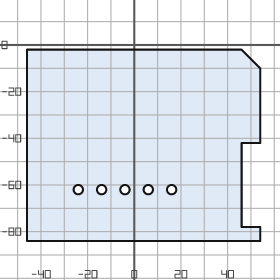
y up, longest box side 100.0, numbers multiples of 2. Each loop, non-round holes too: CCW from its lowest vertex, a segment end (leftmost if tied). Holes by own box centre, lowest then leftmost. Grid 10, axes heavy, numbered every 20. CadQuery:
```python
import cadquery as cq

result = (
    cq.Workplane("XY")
    .moveTo(-46.0, -84.0)
    .lineTo(54.0, -84.0)
    .lineTo(54.0, -78.0)
    .lineTo(46.0, -78.0)
    .lineTo(46.0, -42.0)
    .lineTo(54.0, -42.0)
    .lineTo(54.0, -10.0)
    .lineTo(46.0, -2.0)
    .lineTo(-46.0, -2.0)
    .close()
    .moveTo(-24.0, -62.0)
    .circle(2.0)
    .moveTo(-14.0, -62.0)
    .circle(2.0)
    .moveTo(-4.0, -62.0)
    .circle(2.0)
    .moveTo(6.0, -62.0)
    .circle(2.0)
    .moveTo(16.0, -62.0)
    .circle(2.0)
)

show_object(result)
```